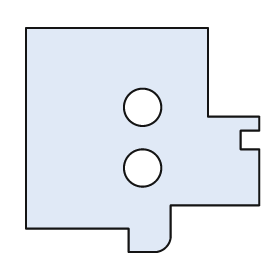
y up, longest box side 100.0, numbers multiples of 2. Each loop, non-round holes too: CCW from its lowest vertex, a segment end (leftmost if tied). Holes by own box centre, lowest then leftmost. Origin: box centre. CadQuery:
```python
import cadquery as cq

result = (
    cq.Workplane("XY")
    .moveTo(-6.0, -48.0)
    .lineTo(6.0, -48.0)
    .threePointArc((10.0, -46.0), (12.0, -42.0))
    .lineTo(12.0, -28.0)
    .lineTo(50.0, -28.0)
    .lineTo(50.0, -4.0)
    .lineTo(42.0, -4.0)
    .lineTo(42.0, 4.0)
    .lineTo(50.0, 4.0)
    .lineTo(50.0, 10.0)
    .lineTo(28.0, 10.0)
    .lineTo(28.0, 48.0)
    .lineTo(-50.0, 48.0)
    .lineTo(-50.0, -38.0)
    .lineTo(-6.0, -38.0)
    .close()
    .moveTo(0.0, -12.0)
    .circle(8.0)
    .moveTo(0.0, 14.0)
    .circle(8.0)
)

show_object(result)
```